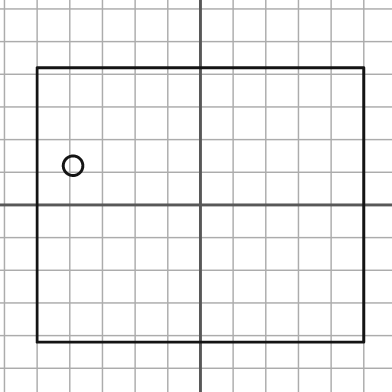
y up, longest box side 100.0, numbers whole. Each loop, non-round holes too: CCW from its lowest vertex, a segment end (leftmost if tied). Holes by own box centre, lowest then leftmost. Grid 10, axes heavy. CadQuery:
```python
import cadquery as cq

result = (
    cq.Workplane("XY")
    .moveTo(-50.0, -42.0)
    .lineTo(50.0, -42.0)
    .lineTo(50.0, 42.0)
    .lineTo(-50.0, 42.0)
    .close()
    .moveTo(-39.0, 12.0)
    .circle(3.0)
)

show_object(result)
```